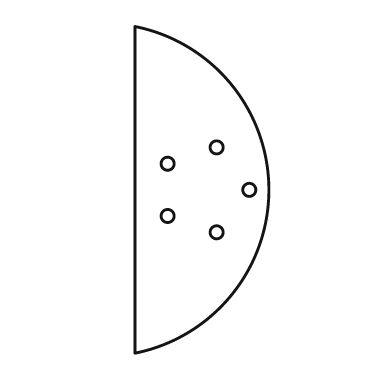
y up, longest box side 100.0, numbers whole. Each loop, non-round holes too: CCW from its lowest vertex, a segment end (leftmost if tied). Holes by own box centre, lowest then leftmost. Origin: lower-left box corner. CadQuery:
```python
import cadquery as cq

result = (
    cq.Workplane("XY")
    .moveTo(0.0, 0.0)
    .threePointArc((41.0, 50.0), (0.0, 100.0))
    .close()
    .moveTo(25.0, 37.0)
    .circle(2.0)
    .moveTo(10.0, 42.0)
    .circle(2.0)
    .moveTo(35.0, 50.0)
    .circle(2.0)
    .moveTo(10.0, 58.0)
    .circle(2.0)
    .moveTo(25.0, 63.0)
    .circle(2.0)
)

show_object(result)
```